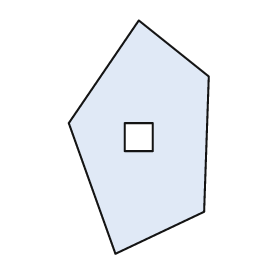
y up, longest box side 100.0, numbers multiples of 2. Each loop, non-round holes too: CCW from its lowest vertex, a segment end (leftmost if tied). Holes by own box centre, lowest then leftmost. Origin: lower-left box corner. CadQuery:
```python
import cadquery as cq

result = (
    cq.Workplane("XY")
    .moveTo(20.0, 0.0)
    .lineTo(58.0, 18.0)
    .lineTo(60.0, 76.0)
    .lineTo(30.0, 100.0)
    .lineTo(0.0, 56.0)
    .close()
    .moveTo(24.0, 44.0)
    .lineTo(36.0, 44.0)
    .lineTo(36.0, 56.0)
    .lineTo(24.0, 56.0)
    .close()
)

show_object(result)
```